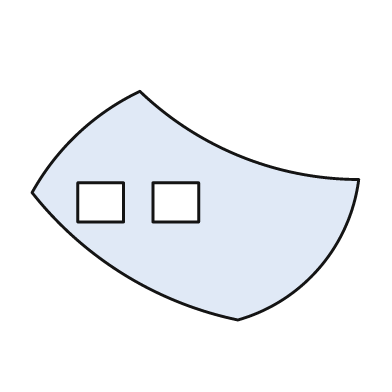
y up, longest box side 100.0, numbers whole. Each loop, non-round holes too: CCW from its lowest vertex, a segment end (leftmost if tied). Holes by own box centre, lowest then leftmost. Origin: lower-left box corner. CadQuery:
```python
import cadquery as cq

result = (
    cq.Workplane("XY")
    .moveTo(63.0, 0.0)
    .threePointArc((88.0, 16.0), (100.0, 43.0))
    .threePointArc((64.0, 50.0), (33.0, 70.0))
    .threePointArc((14.0, 57.0), (0.0, 39.0))
    .threePointArc((28.0, 14.0), (63.0, 0.0))
    .close()
    .moveTo(14.0, 30.0)
    .lineTo(28.0, 30.0)
    .lineTo(28.0, 42.0)
    .lineTo(14.0, 42.0)
    .close()
    .moveTo(37.0, 30.0)
    .lineTo(51.0, 30.0)
    .lineTo(51.0, 42.0)
    .lineTo(37.0, 42.0)
    .close()
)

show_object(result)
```